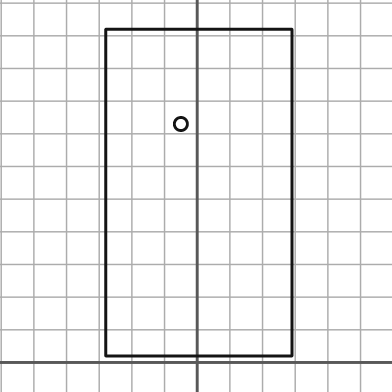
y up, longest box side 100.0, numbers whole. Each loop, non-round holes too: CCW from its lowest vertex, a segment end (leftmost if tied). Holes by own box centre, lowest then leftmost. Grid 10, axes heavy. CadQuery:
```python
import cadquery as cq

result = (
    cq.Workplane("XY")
    .moveTo(-28.0, 2.0)
    .lineTo(29.0, 2.0)
    .lineTo(29.0, 102.0)
    .lineTo(-28.0, 102.0)
    .close()
    .moveTo(-5.0, 73.0)
    .circle(2.0)
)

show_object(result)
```